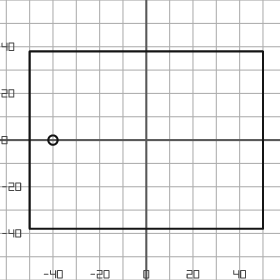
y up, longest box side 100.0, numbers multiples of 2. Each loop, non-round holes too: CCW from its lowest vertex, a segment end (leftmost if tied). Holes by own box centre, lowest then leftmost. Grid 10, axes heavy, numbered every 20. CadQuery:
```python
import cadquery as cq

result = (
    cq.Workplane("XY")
    .moveTo(-50.0, -38.0)
    .lineTo(50.0, -38.0)
    .lineTo(50.0, 38.0)
    .lineTo(-50.0, 38.0)
    .close()
    .moveTo(-40.0, 0.0)
    .circle(2.0)
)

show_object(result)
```